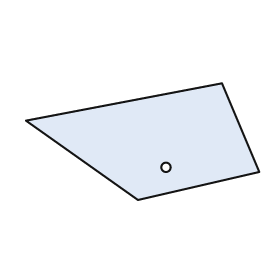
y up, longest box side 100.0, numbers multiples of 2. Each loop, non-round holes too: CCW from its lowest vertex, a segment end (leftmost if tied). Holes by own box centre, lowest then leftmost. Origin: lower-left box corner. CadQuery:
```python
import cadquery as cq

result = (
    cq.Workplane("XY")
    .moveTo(48.0, 0.0)
    .lineTo(100.0, 12.0)
    .lineTo(84.0, 50.0)
    .lineTo(0.0, 34.0)
    .close()
    .moveTo(60.0, 14.0)
    .circle(2.0)
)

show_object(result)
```